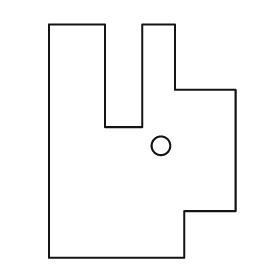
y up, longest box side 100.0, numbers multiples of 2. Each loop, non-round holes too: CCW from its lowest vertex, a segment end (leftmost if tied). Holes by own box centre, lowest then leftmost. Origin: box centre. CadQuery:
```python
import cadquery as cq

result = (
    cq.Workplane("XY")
    .moveTo(-40.0, -50.0)
    .lineTo(18.0, -50.0)
    .lineTo(18.0, -30.0)
    .lineTo(40.0, -30.0)
    .lineTo(40.0, 22.0)
    .lineTo(14.0, 22.0)
    .lineTo(14.0, 50.0)
    .lineTo(0.0, 50.0)
    .lineTo(0.0, 6.0)
    .lineTo(-16.0, 6.0)
    .lineTo(-16.0, 50.0)
    .lineTo(-40.0, 50.0)
    .close()
    .moveTo(8.0, -2.0)
    .circle(4.0)
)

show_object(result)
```